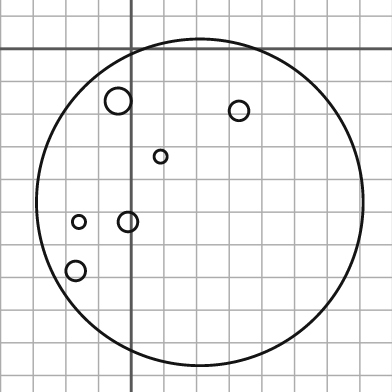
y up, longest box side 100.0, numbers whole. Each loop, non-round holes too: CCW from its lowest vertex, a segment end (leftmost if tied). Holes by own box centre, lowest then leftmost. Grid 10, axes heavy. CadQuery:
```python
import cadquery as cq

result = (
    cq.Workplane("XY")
    .moveTo(21.0, -47.0)
    .circle(50.0)
    .moveTo(-17.0, -68.0)
    .circle(3.0)
    .moveTo(-16.0, -53.0)
    .circle(2.0)
    .moveTo(-1.0, -53.0)
    .circle(3.0)
    .moveTo(9.0, -33.0)
    .circle(2.0)
    .moveTo(33.0, -19.0)
    .circle(3.0)
    .moveTo(-4.0, -16.0)
    .circle(4.0)
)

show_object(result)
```